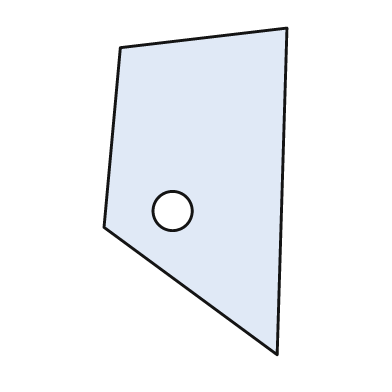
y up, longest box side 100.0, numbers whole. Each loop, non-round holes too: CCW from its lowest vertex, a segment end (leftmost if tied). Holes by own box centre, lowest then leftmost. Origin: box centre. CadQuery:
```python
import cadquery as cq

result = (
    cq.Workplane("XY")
    .moveTo(25.0, -50.0)
    .lineTo(28.0, 50.0)
    .lineTo(-23.0, 44.0)
    .lineTo(-28.0, -11.0)
    .close()
    .moveTo(-7.0, -6.0)
    .circle(6.0)
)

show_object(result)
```